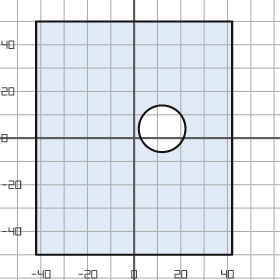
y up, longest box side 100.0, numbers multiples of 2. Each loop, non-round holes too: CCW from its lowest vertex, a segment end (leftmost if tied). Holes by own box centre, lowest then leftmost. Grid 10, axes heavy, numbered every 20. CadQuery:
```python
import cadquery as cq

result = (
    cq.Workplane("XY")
    .moveTo(-42.0, -50.0)
    .lineTo(42.0, -50.0)
    .lineTo(42.0, 50.0)
    .lineTo(-42.0, 50.0)
    .close()
    .moveTo(12.0, 4.0)
    .circle(10.0)
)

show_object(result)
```